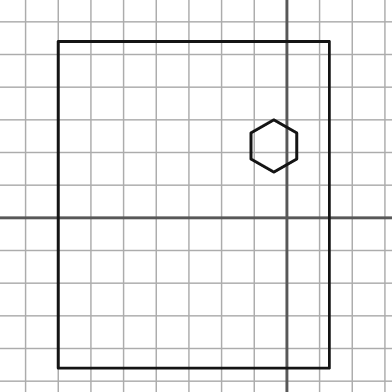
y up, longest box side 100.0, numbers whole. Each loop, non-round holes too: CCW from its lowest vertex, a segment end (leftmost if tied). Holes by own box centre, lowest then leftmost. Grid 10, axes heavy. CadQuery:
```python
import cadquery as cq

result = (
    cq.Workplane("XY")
    .moveTo(-70.0, -46.0)
    .lineTo(13.0, -46.0)
    .lineTo(13.0, 54.0)
    .lineTo(-70.0, 54.0)
    .close()
    .moveTo(-4.0, 14.0)
    .lineTo(3.0, 18.0)
    .lineTo(3.0, 26.0)
    .lineTo(-4.0, 30.0)
    .lineTo(-11.0, 26.0)
    .lineTo(-11.0, 18.0)
    .close()
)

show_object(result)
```